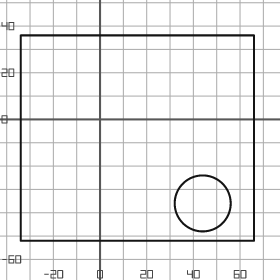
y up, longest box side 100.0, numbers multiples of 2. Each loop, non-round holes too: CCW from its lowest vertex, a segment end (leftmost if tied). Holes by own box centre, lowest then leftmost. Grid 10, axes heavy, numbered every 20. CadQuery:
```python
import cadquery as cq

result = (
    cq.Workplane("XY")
    .moveTo(-34.0, -52.0)
    .lineTo(66.0, -52.0)
    .lineTo(66.0, 36.0)
    .lineTo(-34.0, 36.0)
    .close()
    .moveTo(44.0, -36.0)
    .circle(12.0)
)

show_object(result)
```